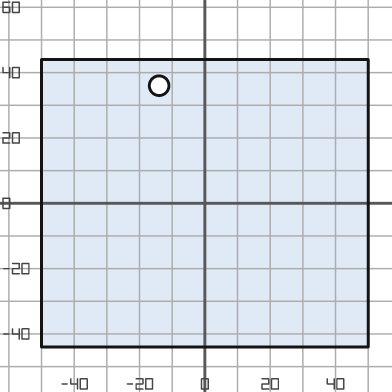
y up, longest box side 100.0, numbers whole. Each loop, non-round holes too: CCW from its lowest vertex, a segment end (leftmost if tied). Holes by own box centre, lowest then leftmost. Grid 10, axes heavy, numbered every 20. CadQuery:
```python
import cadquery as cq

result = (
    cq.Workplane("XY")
    .moveTo(-50.0, -44.0)
    .lineTo(50.0, -44.0)
    .lineTo(50.0, 44.0)
    .lineTo(-50.0, 44.0)
    .close()
    .moveTo(-14.0, 36.0)
    .circle(3.0)
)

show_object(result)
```